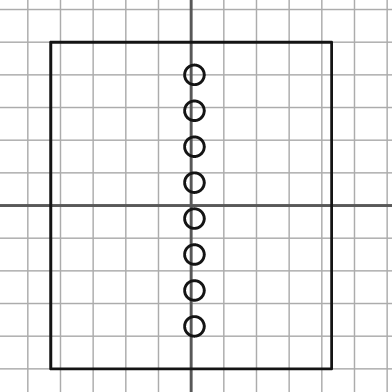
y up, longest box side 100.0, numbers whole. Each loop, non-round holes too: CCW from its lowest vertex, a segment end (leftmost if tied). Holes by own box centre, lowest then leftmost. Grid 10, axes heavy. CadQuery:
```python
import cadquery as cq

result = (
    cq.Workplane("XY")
    .moveTo(-43.0, -50.0)
    .lineTo(43.0, -50.0)
    .lineTo(43.0, 50.0)
    .lineTo(-43.0, 50.0)
    .close()
    .moveTo(1.0, -37.0)
    .circle(3.0)
    .moveTo(1.0, -26.0)
    .circle(3.0)
    .moveTo(1.0, -15.0)
    .circle(3.0)
    .moveTo(1.0, -4.0)
    .circle(3.0)
    .moveTo(1.0, 7.0)
    .circle(3.0)
    .moveTo(1.0, 18.0)
    .circle(3.0)
    .moveTo(1.0, 29.0)
    .circle(3.0)
    .moveTo(1.0, 40.0)
    .circle(3.0)
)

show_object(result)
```